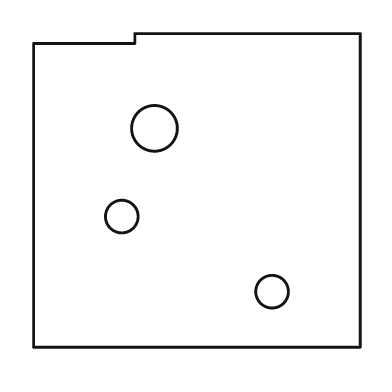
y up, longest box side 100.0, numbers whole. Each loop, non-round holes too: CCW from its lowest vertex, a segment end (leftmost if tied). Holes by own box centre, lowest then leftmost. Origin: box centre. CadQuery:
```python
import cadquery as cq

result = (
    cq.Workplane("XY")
    .moveTo(-50.0, -48.0)
    .lineTo(50.0, -48.0)
    .lineTo(50.0, 48.0)
    .lineTo(-19.0, 48.0)
    .lineTo(-19.0, 45.0)
    .lineTo(-50.0, 45.0)
    .close()
    .moveTo(23.0, -31.0)
    .circle(5.0)
    .moveTo(-23.0, -8.0)
    .circle(5.0)
    .moveTo(-13.0, 19.0)
    .circle(7.0)
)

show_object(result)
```